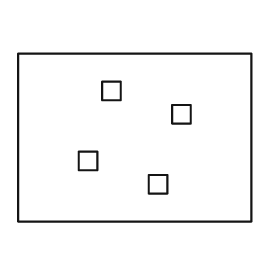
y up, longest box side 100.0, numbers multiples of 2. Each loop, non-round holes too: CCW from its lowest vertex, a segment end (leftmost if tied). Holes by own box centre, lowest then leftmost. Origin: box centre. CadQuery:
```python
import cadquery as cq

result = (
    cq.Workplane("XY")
    .moveTo(-50.0, -36.0)
    .lineTo(50.0, -36.0)
    .lineTo(50.0, 36.0)
    .lineTo(-50.0, 36.0)
    .close()
    .moveTo(6.0, -24.0)
    .lineTo(14.0, -24.0)
    .lineTo(14.0, -16.0)
    .lineTo(6.0, -16.0)
    .close()
    .moveTo(-24.0, -14.0)
    .lineTo(-16.0, -14.0)
    .lineTo(-16.0, -6.0)
    .lineTo(-24.0, -6.0)
    .close()
    .moveTo(16.0, 6.0)
    .lineTo(24.0, 6.0)
    .lineTo(24.0, 14.0)
    .lineTo(16.0, 14.0)
    .close()
    .moveTo(-14.0, 16.0)
    .lineTo(-6.0, 16.0)
    .lineTo(-6.0, 24.0)
    .lineTo(-14.0, 24.0)
    .close()
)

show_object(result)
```